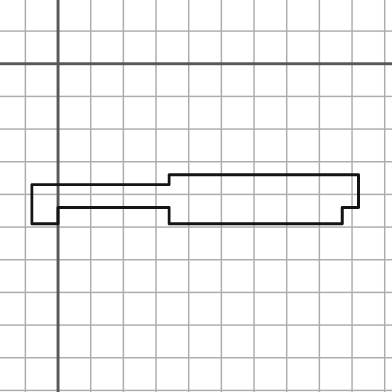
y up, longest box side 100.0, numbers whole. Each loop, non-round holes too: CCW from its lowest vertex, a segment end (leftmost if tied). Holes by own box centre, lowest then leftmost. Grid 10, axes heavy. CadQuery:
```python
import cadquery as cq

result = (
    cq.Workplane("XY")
    .moveTo(-8.0, -49.0)
    .lineTo(0.0, -49.0)
    .lineTo(0.0, -44.0)
    .lineTo(34.0, -44.0)
    .lineTo(34.0, -49.0)
    .lineTo(87.0, -49.0)
    .lineTo(87.0, -44.0)
    .lineTo(92.0, -44.0)
    .lineTo(92.0, -34.0)
    .lineTo(34.0, -34.0)
    .lineTo(34.0, -37.0)
    .lineTo(-8.0, -37.0)
    .close()
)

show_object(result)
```